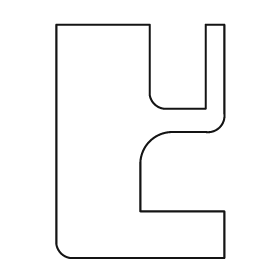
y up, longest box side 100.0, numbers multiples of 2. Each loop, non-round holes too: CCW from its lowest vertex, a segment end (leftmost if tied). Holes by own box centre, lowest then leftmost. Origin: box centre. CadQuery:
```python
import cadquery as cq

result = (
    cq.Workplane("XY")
    .moveTo(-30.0, -50.0)
    .lineTo(36.0, -50.0)
    .lineTo(36.0, -30.0)
    .lineTo(0.0, -30.0)
    .lineTo(0.0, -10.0)
    .threePointArc((4.0, 0.0), (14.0, 4.0))
    .lineTo(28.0, 4.0)
    .threePointArc((34.0, 6.0), (36.0, 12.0))
    .lineTo(36.0, 50.0)
    .lineTo(28.0, 50.0)
    .lineTo(28.0, 14.0)
    .lineTo(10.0, 14.0)
    .threePointArc((6.0, 16.0), (4.0, 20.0))
    .lineTo(4.0, 50.0)
    .lineTo(-36.0, 50.0)
    .lineTo(-36.0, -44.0)
    .threePointArc((-34.0, -48.0), (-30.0, -50.0))
    .close()
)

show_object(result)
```